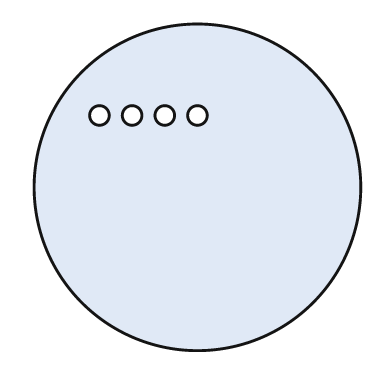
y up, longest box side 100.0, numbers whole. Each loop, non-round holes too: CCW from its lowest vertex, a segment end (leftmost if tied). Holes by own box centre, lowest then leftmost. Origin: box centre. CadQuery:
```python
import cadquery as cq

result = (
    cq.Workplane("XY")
    .moveTo(0.0, 0.0)
    .circle(50.0)
    .moveTo(-30.0, 22.0)
    .circle(3.0)
    .moveTo(-20.0, 22.0)
    .circle(3.0)
    .moveTo(-10.0, 22.0)
    .circle(3.0)
    .moveTo(0.0, 22.0)
    .circle(3.0)
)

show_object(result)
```